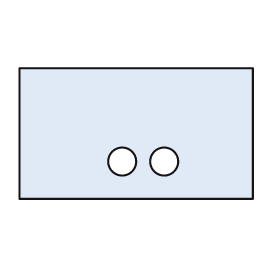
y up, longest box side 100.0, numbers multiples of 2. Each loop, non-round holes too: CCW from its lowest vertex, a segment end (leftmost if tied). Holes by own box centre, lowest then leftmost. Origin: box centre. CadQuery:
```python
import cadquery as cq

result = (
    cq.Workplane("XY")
    .moveTo(-50.0, -28.0)
    .lineTo(50.0, -28.0)
    .lineTo(50.0, 28.0)
    .lineTo(-50.0, 28.0)
    .close()
    .moveTo(-6.0, -12.0)
    .circle(6.0)
    .moveTo(12.0, -12.0)
    .circle(6.0)
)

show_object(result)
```